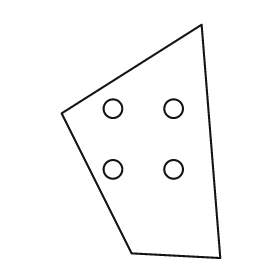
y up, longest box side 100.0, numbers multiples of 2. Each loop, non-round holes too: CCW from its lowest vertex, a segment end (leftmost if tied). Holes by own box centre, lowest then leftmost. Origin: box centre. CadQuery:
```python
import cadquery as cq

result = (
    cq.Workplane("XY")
    .moveTo(34.0, -50.0)
    .lineTo(26.0, 50.0)
    .lineTo(-34.0, 12.0)
    .lineTo(-4.0, -48.0)
    .close()
    .moveTo(-12.0, -12.0)
    .circle(4.0)
    .moveTo(14.0, -12.0)
    .circle(4.0)
    .moveTo(-12.0, 14.0)
    .circle(4.0)
    .moveTo(14.0, 14.0)
    .circle(4.0)
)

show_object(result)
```